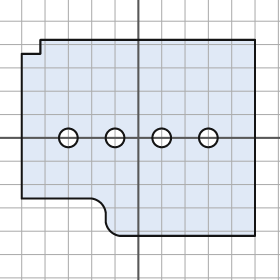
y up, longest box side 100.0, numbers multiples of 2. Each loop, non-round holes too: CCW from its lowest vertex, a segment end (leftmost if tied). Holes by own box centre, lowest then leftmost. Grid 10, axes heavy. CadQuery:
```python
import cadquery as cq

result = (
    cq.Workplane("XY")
    .moveTo(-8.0, -42.0)
    .lineTo(50.0, -42.0)
    .lineTo(50.0, 42.0)
    .lineTo(-42.0, 42.0)
    .lineTo(-42.0, 36.0)
    .lineTo(-50.0, 36.0)
    .lineTo(-50.0, -26.0)
    .lineTo(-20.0, -26.0)
    .threePointArc((-16.0, -28.0), (-14.0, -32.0))
    .lineTo(-14.0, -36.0)
    .threePointArc((-12.0, -40.0), (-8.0, -42.0))
    .close()
    .moveTo(-30.0, 0.0)
    .circle(4.0)
    .moveTo(-10.0, 0.0)
    .circle(4.0)
    .moveTo(10.0, 0.0)
    .circle(4.0)
    .moveTo(30.0, 0.0)
    .circle(4.0)
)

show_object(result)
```